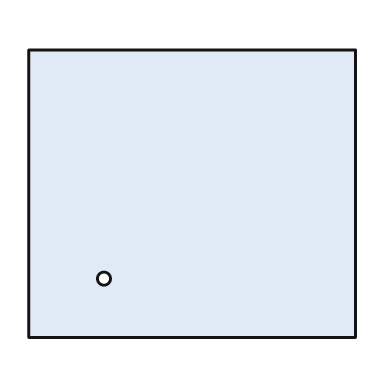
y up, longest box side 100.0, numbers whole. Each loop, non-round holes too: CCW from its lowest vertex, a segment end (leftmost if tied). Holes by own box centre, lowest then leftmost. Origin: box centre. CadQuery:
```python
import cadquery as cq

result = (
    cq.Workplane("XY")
    .moveTo(-50.0, -44.0)
    .lineTo(50.0, -44.0)
    .lineTo(50.0, 44.0)
    .lineTo(-50.0, 44.0)
    .close()
    .moveTo(-27.0, -26.0)
    .circle(2.0)
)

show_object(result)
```